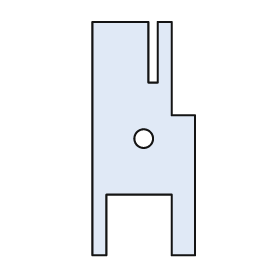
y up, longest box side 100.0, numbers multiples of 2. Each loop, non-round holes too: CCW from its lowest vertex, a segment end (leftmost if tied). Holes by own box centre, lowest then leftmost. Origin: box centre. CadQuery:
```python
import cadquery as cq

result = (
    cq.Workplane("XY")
    .moveTo(-22.0, -50.0)
    .lineTo(-16.0, -50.0)
    .lineTo(-16.0, -24.0)
    .lineTo(12.0, -24.0)
    .lineTo(12.0, -50.0)
    .lineTo(22.0, -50.0)
    .lineTo(22.0, 10.0)
    .lineTo(12.0, 10.0)
    .lineTo(12.0, 50.0)
    .lineTo(6.0, 50.0)
    .lineTo(6.0, 24.0)
    .lineTo(2.0, 24.0)
    .lineTo(2.0, 50.0)
    .lineTo(-22.0, 50.0)
    .close()
    .moveTo(0.0, 0.0)
    .circle(4.0)
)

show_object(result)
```